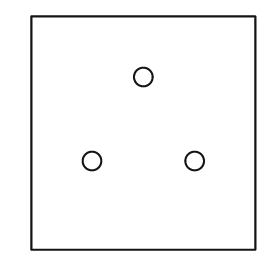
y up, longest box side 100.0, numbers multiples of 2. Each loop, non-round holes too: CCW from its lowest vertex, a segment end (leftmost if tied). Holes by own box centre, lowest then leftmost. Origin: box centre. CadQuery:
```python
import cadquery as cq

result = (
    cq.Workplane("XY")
    .moveTo(-48.0, -50.0)
    .lineTo(48.0, -50.0)
    .lineTo(48.0, 50.0)
    .lineTo(-48.0, 50.0)
    .close()
    .moveTo(-22.0, -12.0)
    .circle(4.0)
    .moveTo(22.0, -12.0)
    .circle(4.0)
    .moveTo(0.0, 24.0)
    .circle(4.0)
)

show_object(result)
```